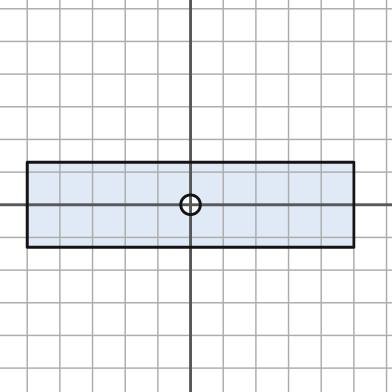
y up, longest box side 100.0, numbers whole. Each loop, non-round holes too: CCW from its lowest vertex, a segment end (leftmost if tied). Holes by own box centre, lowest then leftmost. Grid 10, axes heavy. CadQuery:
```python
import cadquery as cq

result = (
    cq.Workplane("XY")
    .moveTo(-50.0, -13.0)
    .lineTo(50.0, -13.0)
    .lineTo(50.0, 13.0)
    .lineTo(-50.0, 13.0)
    .close()
    .moveTo(0.0, 0.0)
    .circle(3.0)
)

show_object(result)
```